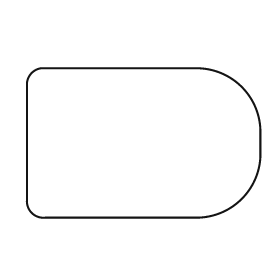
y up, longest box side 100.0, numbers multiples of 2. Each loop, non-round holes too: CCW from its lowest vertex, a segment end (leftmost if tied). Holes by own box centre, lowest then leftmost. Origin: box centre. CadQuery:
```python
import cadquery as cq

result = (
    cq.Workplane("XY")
    .moveTo(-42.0, -32.0)
    .lineTo(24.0, -32.0)
    .threePointArc((42.0, -24.0), (50.0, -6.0))
    .lineTo(50.0, 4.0)
    .threePointArc((42.0, 24.0), (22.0, 32.0))
    .lineTo(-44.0, 32.0)
    .threePointArc((-48.0, 30.0), (-50.0, 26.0))
    .lineTo(-50.0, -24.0)
    .threePointArc((-48.0, -30.0), (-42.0, -32.0))
    .close()
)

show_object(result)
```